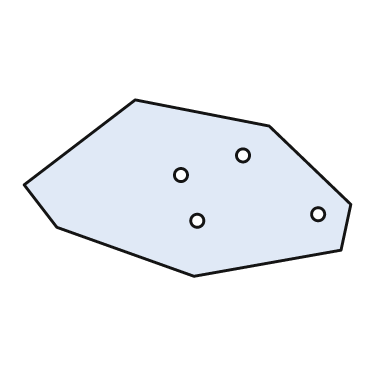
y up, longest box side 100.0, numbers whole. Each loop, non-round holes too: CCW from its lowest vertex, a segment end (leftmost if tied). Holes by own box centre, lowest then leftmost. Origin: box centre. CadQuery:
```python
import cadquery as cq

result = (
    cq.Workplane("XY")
    .moveTo(2.0, -27.0)
    .lineTo(47.0, -19.0)
    .lineTo(50.0, -5.0)
    .lineTo(25.0, 19.0)
    .lineTo(-16.0, 27.0)
    .lineTo(-50.0, 1.0)
    .lineTo(-40.0, -12.0)
    .close()
    .moveTo(3.0, -10.0)
    .circle(2.0)
    .moveTo(40.0, -8.0)
    .circle(2.0)
    .moveTo(-2.0, 4.0)
    .circle(2.0)
    .moveTo(17.0, 10.0)
    .circle(2.0)
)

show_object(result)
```